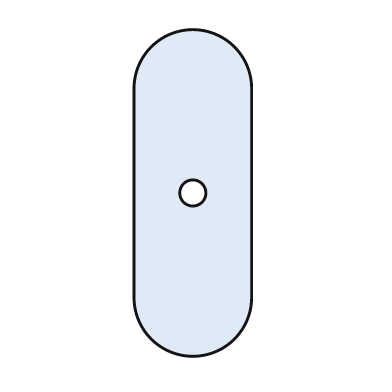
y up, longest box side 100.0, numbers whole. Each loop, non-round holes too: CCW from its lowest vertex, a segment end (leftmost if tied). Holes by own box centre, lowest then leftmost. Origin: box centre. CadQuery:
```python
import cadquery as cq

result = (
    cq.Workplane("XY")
    .moveTo(-18.0, -32.0)
    .threePointArc((0.0, -50.0), (18.0, -32.0))
    .lineTo(18.0, 32.0)
    .threePointArc((0.0, 50.0), (-18.0, 32.0))
    .close()
    .moveTo(0.0, 0.0)
    .circle(4.0)
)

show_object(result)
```